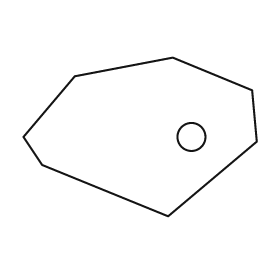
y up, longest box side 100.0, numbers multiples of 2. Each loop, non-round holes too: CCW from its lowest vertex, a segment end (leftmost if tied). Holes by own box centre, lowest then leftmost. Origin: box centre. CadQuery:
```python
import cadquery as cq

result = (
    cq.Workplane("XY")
    .moveTo(12.0, -34.0)
    .lineTo(50.0, -2.0)
    .lineTo(48.0, 20.0)
    .lineTo(14.0, 34.0)
    .lineTo(-28.0, 26.0)
    .lineTo(-50.0, 0.0)
    .lineTo(-42.0, -12.0)
    .close()
    .moveTo(22.0, 0.0)
    .circle(6.0)
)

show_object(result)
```